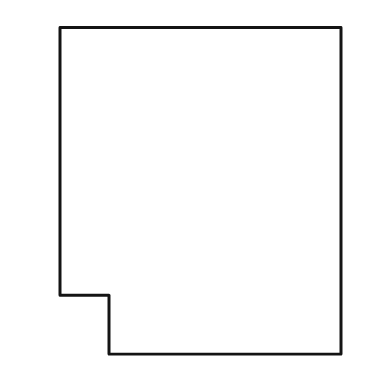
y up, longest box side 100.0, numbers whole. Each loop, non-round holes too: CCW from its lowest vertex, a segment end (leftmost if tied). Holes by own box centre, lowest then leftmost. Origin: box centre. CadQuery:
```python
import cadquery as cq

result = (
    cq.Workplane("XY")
    .moveTo(-28.0, -50.0)
    .lineTo(43.0, -50.0)
    .lineTo(43.0, 50.0)
    .lineTo(-43.0, 50.0)
    .lineTo(-43.0, -32.0)
    .lineTo(-28.0, -32.0)
    .close()
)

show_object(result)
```